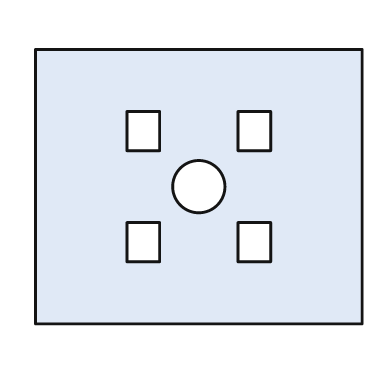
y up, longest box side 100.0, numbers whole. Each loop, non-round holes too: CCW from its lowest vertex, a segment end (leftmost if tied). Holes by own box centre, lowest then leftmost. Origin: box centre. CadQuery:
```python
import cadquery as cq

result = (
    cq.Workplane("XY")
    .moveTo(-50.0, -42.0)
    .lineTo(50.0, -42.0)
    .lineTo(50.0, 42.0)
    .lineTo(-50.0, 42.0)
    .close()
    .moveTo(-22.0, -23.0)
    .lineTo(-12.0, -23.0)
    .lineTo(-12.0, -11.0)
    .lineTo(-22.0, -11.0)
    .close()
    .moveTo(12.0, -23.0)
    .lineTo(22.0, -23.0)
    .lineTo(22.0, -11.0)
    .lineTo(12.0, -11.0)
    .close()
    .moveTo(0.0, 0.0)
    .circle(8.0)
    .moveTo(-22.0, 11.0)
    .lineTo(-12.0, 11.0)
    .lineTo(-12.0, 23.0)
    .lineTo(-22.0, 23.0)
    .close()
    .moveTo(12.0, 11.0)
    .lineTo(22.0, 11.0)
    .lineTo(22.0, 23.0)
    .lineTo(12.0, 23.0)
    .close()
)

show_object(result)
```